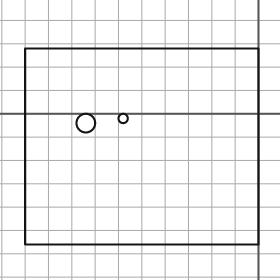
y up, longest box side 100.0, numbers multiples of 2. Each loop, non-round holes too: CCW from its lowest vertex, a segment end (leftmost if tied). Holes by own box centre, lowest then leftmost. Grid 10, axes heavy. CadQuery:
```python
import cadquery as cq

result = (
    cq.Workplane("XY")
    .moveTo(-100.0, -56.0)
    .lineTo(0.0, -56.0)
    .lineTo(0.0, 28.0)
    .lineTo(-100.0, 28.0)
    .close()
    .moveTo(-74.0, -4.0)
    .circle(4.0)
    .moveTo(-58.0, -2.0)
    .circle(2.0)
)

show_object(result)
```